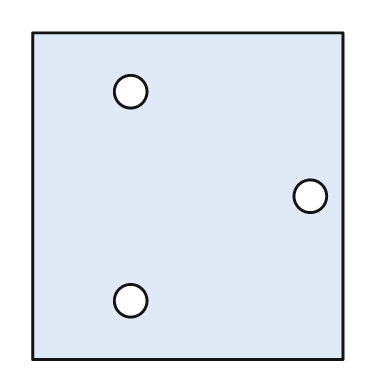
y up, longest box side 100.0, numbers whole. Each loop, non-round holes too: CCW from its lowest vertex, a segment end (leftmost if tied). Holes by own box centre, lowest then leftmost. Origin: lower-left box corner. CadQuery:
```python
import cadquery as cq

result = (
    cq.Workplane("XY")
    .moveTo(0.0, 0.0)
    .lineTo(95.0, 0.0)
    .lineTo(95.0, 100.0)
    .lineTo(0.0, 100.0)
    .close()
    .moveTo(30.0, 18.0)
    .circle(5.0)
    .moveTo(85.0, 50.0)
    .circle(5.0)
    .moveTo(30.0, 82.0)
    .circle(5.0)
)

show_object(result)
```